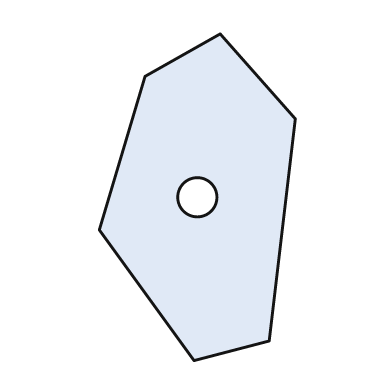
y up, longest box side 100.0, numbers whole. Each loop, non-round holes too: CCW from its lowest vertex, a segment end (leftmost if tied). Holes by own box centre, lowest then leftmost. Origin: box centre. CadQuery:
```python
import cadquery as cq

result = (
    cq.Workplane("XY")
    .moveTo(-1.0, -50.0)
    .lineTo(22.0, -44.0)
    .lineTo(30.0, 24.0)
    .lineTo(7.0, 50.0)
    .lineTo(-16.0, 37.0)
    .lineTo(-30.0, -10.0)
    .close()
    .moveTo(0.0, 0.0)
    .circle(6.0)
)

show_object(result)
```